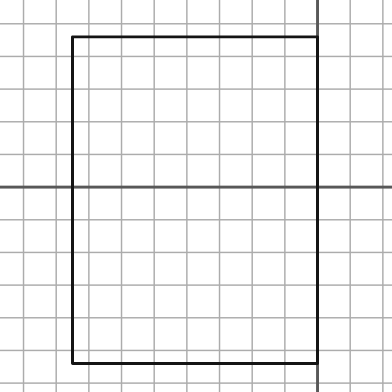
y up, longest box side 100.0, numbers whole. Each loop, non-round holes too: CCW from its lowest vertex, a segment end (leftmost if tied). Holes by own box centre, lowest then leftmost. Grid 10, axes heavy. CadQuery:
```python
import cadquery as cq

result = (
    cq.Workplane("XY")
    .moveTo(-75.0, -54.0)
    .lineTo(0.0, -54.0)
    .lineTo(0.0, 46.0)
    .lineTo(-75.0, 46.0)
    .close()
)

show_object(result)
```